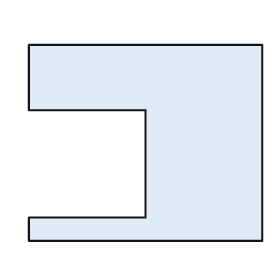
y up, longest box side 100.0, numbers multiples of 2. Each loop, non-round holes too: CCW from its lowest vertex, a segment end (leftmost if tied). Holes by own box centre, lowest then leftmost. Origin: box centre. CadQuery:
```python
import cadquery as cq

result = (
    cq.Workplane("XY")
    .moveTo(-50.0, -42.0)
    .lineTo(50.0, -42.0)
    .lineTo(50.0, 42.0)
    .lineTo(-50.0, 42.0)
    .lineTo(-50.0, 14.0)
    .lineTo(0.0, 14.0)
    .lineTo(0.0, -32.0)
    .lineTo(-50.0, -32.0)
    .close()
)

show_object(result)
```